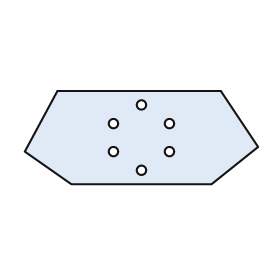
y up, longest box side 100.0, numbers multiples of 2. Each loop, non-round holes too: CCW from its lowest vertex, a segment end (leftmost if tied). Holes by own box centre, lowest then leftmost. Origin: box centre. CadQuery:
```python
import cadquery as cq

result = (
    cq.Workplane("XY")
    .moveTo(-30.0, -20.0)
    .lineTo(30.0, -20.0)
    .lineTo(50.0, -4.0)
    .lineTo(34.0, 20.0)
    .lineTo(-36.0, 20.0)
    .lineTo(-50.0, -6.0)
    .close()
    .moveTo(0.0, -14.0)
    .circle(2.0)
    .moveTo(-12.0, -6.0)
    .circle(2.0)
    .moveTo(12.0, -6.0)
    .circle(2.0)
    .moveTo(-12.0, 6.0)
    .circle(2.0)
    .moveTo(12.0, 6.0)
    .circle(2.0)
    .moveTo(0.0, 14.0)
    .circle(2.0)
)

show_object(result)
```